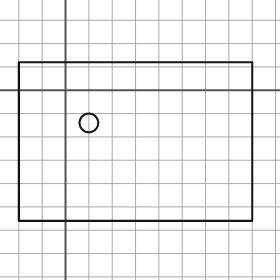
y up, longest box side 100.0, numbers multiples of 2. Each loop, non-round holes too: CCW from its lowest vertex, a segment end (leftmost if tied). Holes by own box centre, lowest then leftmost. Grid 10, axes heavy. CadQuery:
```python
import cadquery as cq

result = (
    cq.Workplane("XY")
    .moveTo(-20.0, -56.0)
    .lineTo(80.0, -56.0)
    .lineTo(80.0, 12.0)
    .lineTo(-20.0, 12.0)
    .close()
    .moveTo(10.0, -14.0)
    .circle(4.0)
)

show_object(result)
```